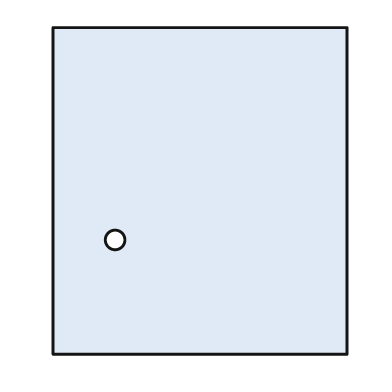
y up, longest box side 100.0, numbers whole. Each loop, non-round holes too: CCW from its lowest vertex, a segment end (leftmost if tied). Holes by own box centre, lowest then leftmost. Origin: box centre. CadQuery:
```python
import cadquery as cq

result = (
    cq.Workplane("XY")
    .moveTo(-45.0, -50.0)
    .lineTo(45.0, -50.0)
    .lineTo(45.0, 50.0)
    .lineTo(-45.0, 50.0)
    .close()
    .moveTo(-26.0, -15.0)
    .circle(3.0)
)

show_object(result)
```